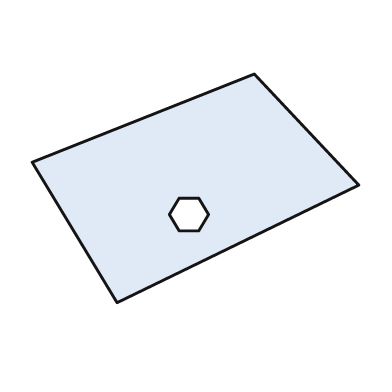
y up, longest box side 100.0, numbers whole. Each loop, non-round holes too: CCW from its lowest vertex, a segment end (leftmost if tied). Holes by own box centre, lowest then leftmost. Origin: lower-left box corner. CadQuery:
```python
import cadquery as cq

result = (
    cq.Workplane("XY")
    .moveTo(26.0, 0.0)
    .lineTo(100.0, 36.0)
    .lineTo(68.0, 70.0)
    .lineTo(0.0, 43.0)
    .close()
    .moveTo(45.0, 22.0)
    .lineTo(51.0, 22.0)
    .lineTo(54.0, 27.0)
    .lineTo(51.0, 32.0)
    .lineTo(45.0, 32.0)
    .lineTo(42.0, 27.0)
    .close()
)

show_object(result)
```